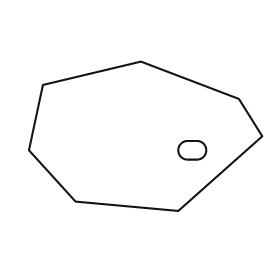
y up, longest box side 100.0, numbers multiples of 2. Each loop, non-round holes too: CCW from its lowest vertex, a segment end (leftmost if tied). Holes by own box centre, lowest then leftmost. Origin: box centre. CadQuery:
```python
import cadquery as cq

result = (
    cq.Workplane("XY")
    .moveTo(14.0, -32.0)
    .lineTo(50.0, 0.0)
    .lineTo(40.0, 16.0)
    .lineTo(-2.0, 32.0)
    .lineTo(-44.0, 22.0)
    .lineTo(-50.0, -6.0)
    .lineTo(-30.0, -28.0)
    .close()
    .moveTo(18.0, -10.0)
    .lineTo(22.0, -10.0)
    .threePointArc((26.0, -6.0), (22.0, -2.0))
    .lineTo(18.0, -2.0)
    .threePointArc((14.0, -6.0), (18.0, -10.0))
    .close()
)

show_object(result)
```